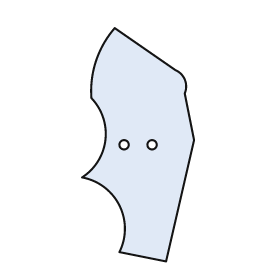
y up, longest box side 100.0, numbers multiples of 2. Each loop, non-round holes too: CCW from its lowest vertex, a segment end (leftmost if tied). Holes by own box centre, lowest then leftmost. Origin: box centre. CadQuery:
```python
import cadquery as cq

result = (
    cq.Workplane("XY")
    .moveTo(12.0, -50.0)
    .lineTo(24.0, 2.0)
    .lineTo(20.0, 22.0)
    .threePointArc((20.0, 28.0), (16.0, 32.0))
    .lineTo(-10.0, 50.0)
    .threePointArc((-18.0, 36.0), (-20.0, 20.0))
    .threePointArc((-14.0, 2.0), (-24.0, -14.0))
    .threePointArc((-8.0, -26.0), (-8.0, -46.0))
    .close()
    .moveTo(-6.0, 0.0)
    .circle(2.0)
    .moveTo(6.0, 0.0)
    .circle(2.0)
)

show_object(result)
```